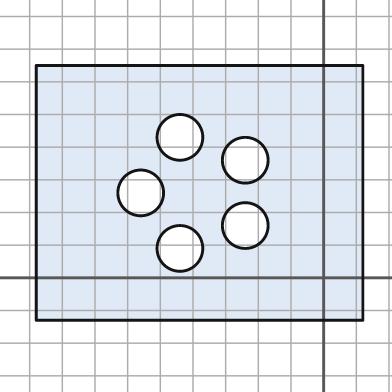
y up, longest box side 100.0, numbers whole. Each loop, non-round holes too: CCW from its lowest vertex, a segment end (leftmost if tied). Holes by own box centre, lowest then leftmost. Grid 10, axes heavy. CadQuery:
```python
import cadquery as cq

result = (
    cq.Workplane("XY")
    .moveTo(-88.0, -13.0)
    .lineTo(12.0, -13.0)
    .lineTo(12.0, 65.0)
    .lineTo(-88.0, 65.0)
    .close()
    .moveTo(-44.0, 9.0)
    .circle(7.0)
    .moveTo(-24.0, 16.0)
    .circle(7.0)
    .moveTo(-56.0, 26.0)
    .circle(7.0)
    .moveTo(-24.0, 36.0)
    .circle(7.0)
    .moveTo(-44.0, 43.0)
    .circle(7.0)
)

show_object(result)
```